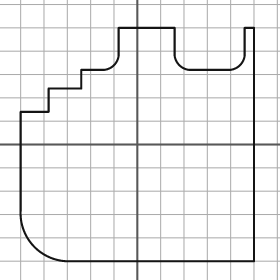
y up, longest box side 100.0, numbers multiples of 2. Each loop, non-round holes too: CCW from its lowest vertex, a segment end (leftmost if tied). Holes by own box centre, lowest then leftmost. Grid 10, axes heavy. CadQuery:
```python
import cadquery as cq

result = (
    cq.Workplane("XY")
    .moveTo(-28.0, -50.0)
    .lineTo(50.0, -50.0)
    .lineTo(50.0, 50.0)
    .lineTo(46.0, 50.0)
    .lineTo(46.0, 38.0)
    .threePointArc((44.0, 34.0), (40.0, 32.0))
    .lineTo(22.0, 32.0)
    .threePointArc((18.0, 34.0), (16.0, 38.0))
    .lineTo(16.0, 50.0)
    .lineTo(-8.0, 50.0)
    .lineTo(-8.0, 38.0)
    .threePointArc((-10.0, 34.0), (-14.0, 32.0))
    .lineTo(-24.0, 32.0)
    .lineTo(-24.0, 24.0)
    .lineTo(-38.0, 24.0)
    .lineTo(-38.0, 14.0)
    .lineTo(-50.0, 14.0)
    .lineTo(-50.0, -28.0)
    .threePointArc((-44.0, -44.0), (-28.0, -50.0))
    .close()
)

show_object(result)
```